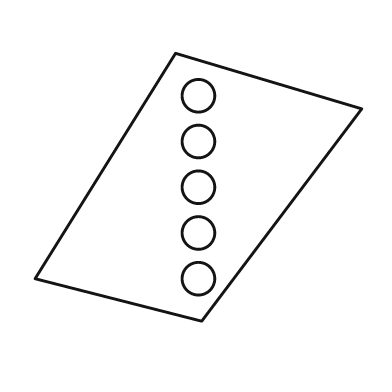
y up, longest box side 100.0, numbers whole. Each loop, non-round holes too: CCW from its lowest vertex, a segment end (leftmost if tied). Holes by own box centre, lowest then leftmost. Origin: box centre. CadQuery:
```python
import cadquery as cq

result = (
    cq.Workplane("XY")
    .moveTo(1.0, -41.0)
    .lineTo(50.0, 24.0)
    .lineTo(-7.0, 41.0)
    .lineTo(-50.0, -28.0)
    .close()
    .moveTo(0.0, -28.0)
    .circle(5.0)
    .moveTo(0.0, -14.0)
    .circle(5.0)
    .moveTo(0.0, 0.0)
    .circle(5.0)
    .moveTo(0.0, 14.0)
    .circle(5.0)
    .moveTo(0.0, 28.0)
    .circle(5.0)
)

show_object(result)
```